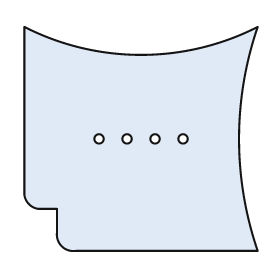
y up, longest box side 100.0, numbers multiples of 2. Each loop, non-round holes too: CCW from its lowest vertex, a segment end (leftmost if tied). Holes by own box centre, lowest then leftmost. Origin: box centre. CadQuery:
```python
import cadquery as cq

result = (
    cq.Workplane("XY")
    .moveTo(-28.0, -48.0)
    .lineTo(50.0, -48.0)
    .threePointArc((42.0, 0.0), (50.0, 48.0))
    .threePointArc((0.0, 36.0), (-50.0, 48.0))
    .lineTo(-50.0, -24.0)
    .threePointArc((-48.0, -28.0), (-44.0, -30.0))
    .lineTo(-36.0, -30.0)
    .lineTo(-36.0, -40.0)
    .threePointArc((-34.0, -46.0), (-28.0, -48.0))
    .close()
    .moveTo(-18.0, 0.0)
    .circle(2.0)
    .moveTo(-6.0, 0.0)
    .circle(2.0)
    .moveTo(6.0, 0.0)
    .circle(2.0)
    .moveTo(18.0, 0.0)
    .circle(2.0)
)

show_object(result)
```